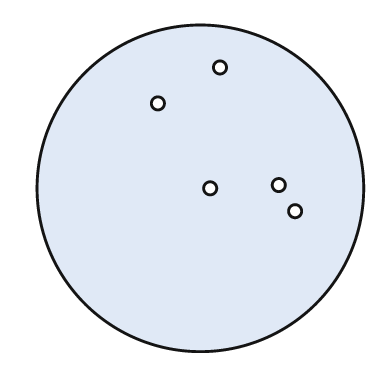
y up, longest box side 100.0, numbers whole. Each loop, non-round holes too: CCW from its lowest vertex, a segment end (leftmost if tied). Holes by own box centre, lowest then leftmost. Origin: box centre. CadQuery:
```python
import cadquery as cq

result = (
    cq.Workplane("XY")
    .moveTo(0.0, 0.0)
    .circle(50.0)
    .moveTo(29.0, -7.0)
    .circle(2.0)
    .moveTo(3.0, 0.0)
    .circle(2.0)
    .moveTo(24.0, 1.0)
    .circle(2.0)
    .moveTo(-13.0, 26.0)
    .circle(2.0)
    .moveTo(6.0, 37.0)
    .circle(2.0)
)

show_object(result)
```